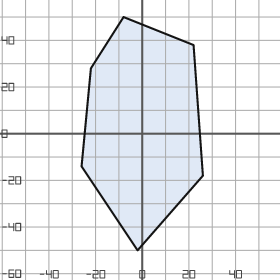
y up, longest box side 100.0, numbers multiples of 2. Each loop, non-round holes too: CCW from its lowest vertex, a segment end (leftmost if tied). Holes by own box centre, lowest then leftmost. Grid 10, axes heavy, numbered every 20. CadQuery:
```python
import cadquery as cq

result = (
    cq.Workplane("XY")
    .moveTo(-2.0, -50.0)
    .lineTo(26.0, -18.0)
    .lineTo(22.0, 38.0)
    .lineTo(-8.0, 50.0)
    .lineTo(-22.0, 28.0)
    .lineTo(-26.0, -14.0)
    .close()
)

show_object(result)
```